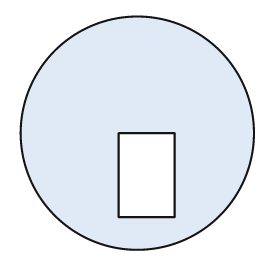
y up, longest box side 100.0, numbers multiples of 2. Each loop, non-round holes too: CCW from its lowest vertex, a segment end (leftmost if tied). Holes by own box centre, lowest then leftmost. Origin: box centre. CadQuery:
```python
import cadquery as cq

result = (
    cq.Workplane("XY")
    .moveTo(0.0, 0.0)
    .circle(50.0)
    .moveTo(-8.0, -36.0)
    .lineTo(16.0, -36.0)
    .lineTo(16.0, 0.0)
    .lineTo(-8.0, 0.0)
    .close()
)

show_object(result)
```